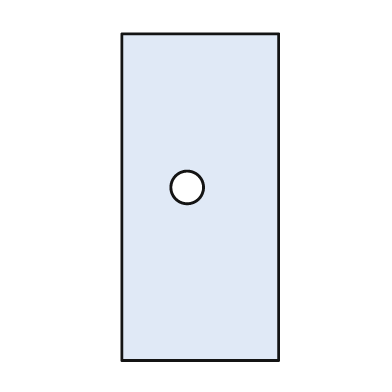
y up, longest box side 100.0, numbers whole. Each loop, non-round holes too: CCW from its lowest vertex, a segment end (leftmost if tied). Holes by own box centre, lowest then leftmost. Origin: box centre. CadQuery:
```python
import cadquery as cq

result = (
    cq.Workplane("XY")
    .moveTo(-24.0, -50.0)
    .lineTo(24.0, -50.0)
    .lineTo(24.0, 50.0)
    .lineTo(-24.0, 50.0)
    .close()
    .moveTo(-4.0, 3.0)
    .circle(5.0)
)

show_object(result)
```